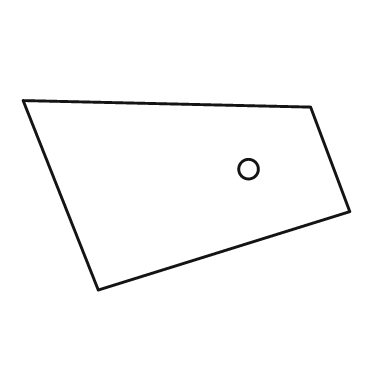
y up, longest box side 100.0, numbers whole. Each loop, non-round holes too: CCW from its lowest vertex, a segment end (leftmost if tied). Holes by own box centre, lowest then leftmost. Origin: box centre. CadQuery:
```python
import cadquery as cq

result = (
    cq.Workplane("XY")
    .moveTo(-27.0, -29.0)
    .lineTo(50.0, -5.0)
    .lineTo(38.0, 27.0)
    .lineTo(-50.0, 29.0)
    .close()
    .moveTo(19.0, 8.0)
    .circle(3.0)
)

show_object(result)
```